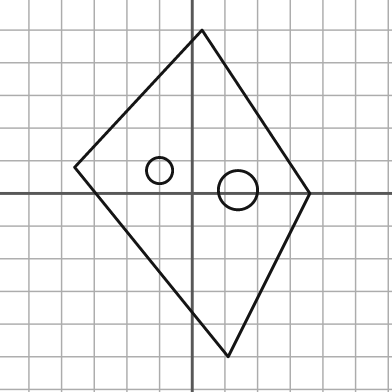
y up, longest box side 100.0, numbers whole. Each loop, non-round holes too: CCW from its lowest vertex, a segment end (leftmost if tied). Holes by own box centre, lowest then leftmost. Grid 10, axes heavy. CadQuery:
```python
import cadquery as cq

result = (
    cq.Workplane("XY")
    .moveTo(11.0, -50.0)
    .lineTo(36.0, 0.0)
    .lineTo(3.0, 50.0)
    .lineTo(-36.0, 8.0)
    .close()
    .moveTo(14.0, 1.0)
    .circle(6.0)
    .moveTo(-10.0, 7.0)
    .circle(4.0)
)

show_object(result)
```